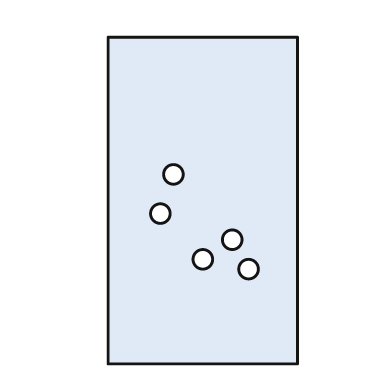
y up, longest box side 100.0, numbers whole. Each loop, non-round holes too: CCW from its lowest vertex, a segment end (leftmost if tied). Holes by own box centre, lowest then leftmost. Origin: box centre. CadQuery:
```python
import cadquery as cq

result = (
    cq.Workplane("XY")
    .moveTo(-29.0, -50.0)
    .lineTo(29.0, -50.0)
    .lineTo(29.0, 50.0)
    .lineTo(-29.0, 50.0)
    .close()
    .moveTo(14.0, -21.0)
    .circle(3.0)
    .moveTo(0.0, -18.0)
    .circle(3.0)
    .moveTo(9.0, -12.0)
    .circle(3.0)
    .moveTo(-13.0, -4.0)
    .circle(3.0)
    .moveTo(-9.0, 8.0)
    .circle(3.0)
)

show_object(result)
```